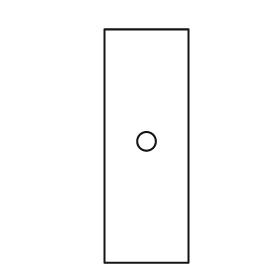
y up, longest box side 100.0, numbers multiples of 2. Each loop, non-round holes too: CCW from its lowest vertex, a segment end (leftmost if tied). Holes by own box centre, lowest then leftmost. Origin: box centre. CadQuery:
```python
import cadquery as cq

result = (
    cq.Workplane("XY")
    .moveTo(-18.0, -50.0)
    .lineTo(18.0, -50.0)
    .lineTo(18.0, 50.0)
    .lineTo(-18.0, 50.0)
    .close()
    .moveTo(0.0, 2.0)
    .circle(4.0)
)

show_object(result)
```